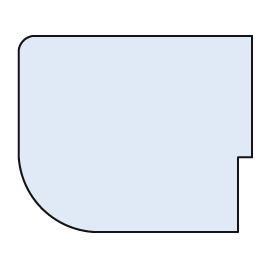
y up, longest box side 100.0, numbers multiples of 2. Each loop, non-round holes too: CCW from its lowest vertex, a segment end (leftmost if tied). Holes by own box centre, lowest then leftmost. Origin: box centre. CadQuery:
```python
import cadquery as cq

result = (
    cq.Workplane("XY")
    .moveTo(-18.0, -42.0)
    .lineTo(44.0, -42.0)
    .lineTo(44.0, -10.0)
    .lineTo(50.0, -10.0)
    .lineTo(50.0, 42.0)
    .lineTo(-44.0, 42.0)
    .threePointArc((-48.0, 40.0), (-50.0, 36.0))
    .lineTo(-50.0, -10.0)
    .threePointArc((-40.0, -32.0), (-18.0, -42.0))
    .close()
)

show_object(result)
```